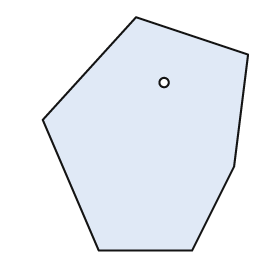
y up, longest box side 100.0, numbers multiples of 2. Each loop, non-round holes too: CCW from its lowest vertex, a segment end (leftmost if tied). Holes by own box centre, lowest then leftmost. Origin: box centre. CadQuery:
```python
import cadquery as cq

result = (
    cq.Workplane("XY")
    .moveTo(-20.0, -50.0)
    .lineTo(20.0, -50.0)
    .lineTo(38.0, -14.0)
    .lineTo(44.0, 34.0)
    .lineTo(-4.0, 50.0)
    .lineTo(-44.0, 6.0)
    .close()
    .moveTo(8.0, 22.0)
    .circle(2.0)
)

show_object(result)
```